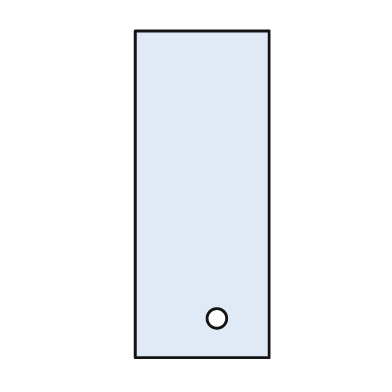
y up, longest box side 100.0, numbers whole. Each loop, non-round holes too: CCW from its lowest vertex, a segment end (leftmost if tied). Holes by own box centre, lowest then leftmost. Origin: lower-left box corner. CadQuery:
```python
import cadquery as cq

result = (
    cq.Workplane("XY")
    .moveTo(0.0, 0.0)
    .lineTo(41.0, 0.0)
    .lineTo(41.0, 100.0)
    .lineTo(0.0, 100.0)
    .close()
    .moveTo(25.0, 12.0)
    .circle(3.0)
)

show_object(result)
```